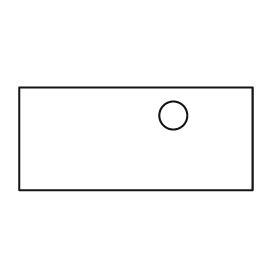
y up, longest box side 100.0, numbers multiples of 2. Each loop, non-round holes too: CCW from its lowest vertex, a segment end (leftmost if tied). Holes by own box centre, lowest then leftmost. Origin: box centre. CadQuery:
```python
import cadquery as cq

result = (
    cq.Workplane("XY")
    .moveTo(-50.0, -22.0)
    .lineTo(50.0, -22.0)
    .lineTo(50.0, 22.0)
    .lineTo(-50.0, 22.0)
    .close()
    .moveTo(16.0, 10.0)
    .circle(6.0)
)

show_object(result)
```